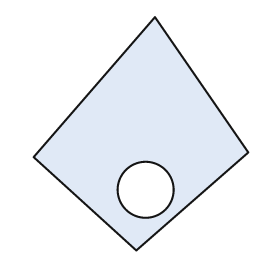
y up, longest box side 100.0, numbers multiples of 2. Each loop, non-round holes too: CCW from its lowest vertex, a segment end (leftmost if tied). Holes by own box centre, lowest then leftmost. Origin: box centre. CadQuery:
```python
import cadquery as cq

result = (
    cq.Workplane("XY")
    .moveTo(-2.0, -50.0)
    .lineTo(46.0, -8.0)
    .lineTo(6.0, 50.0)
    .lineTo(-46.0, -10.0)
    .close()
    .moveTo(2.0, -24.0)
    .circle(12.0)
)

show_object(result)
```